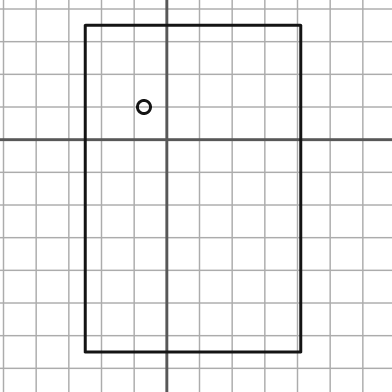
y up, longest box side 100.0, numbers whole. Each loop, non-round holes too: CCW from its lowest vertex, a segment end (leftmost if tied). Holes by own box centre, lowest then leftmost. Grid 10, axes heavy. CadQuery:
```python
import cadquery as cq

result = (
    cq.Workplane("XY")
    .moveTo(-25.0, -65.0)
    .lineTo(41.0, -65.0)
    .lineTo(41.0, 35.0)
    .lineTo(-25.0, 35.0)
    .close()
    .moveTo(-7.0, 10.0)
    .circle(2.0)
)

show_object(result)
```